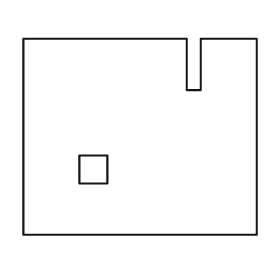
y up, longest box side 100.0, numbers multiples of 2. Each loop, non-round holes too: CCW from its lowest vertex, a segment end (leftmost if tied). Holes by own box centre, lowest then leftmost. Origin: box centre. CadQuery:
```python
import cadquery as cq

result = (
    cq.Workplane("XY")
    .moveTo(-50.0, -42.0)
    .lineTo(50.0, -42.0)
    .lineTo(50.0, 42.0)
    .lineTo(26.0, 42.0)
    .lineTo(26.0, 20.0)
    .lineTo(20.0, 20.0)
    .lineTo(20.0, 42.0)
    .lineTo(-50.0, 42.0)
    .close()
    .moveTo(-26.0, -20.0)
    .lineTo(-14.0, -20.0)
    .lineTo(-14.0, -8.0)
    .lineTo(-26.0, -8.0)
    .close()
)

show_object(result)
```